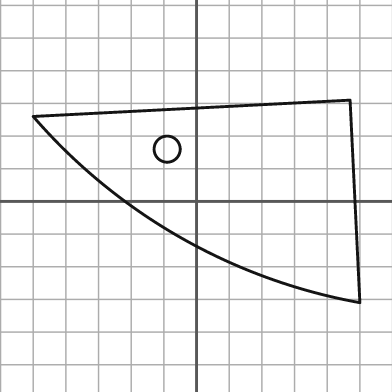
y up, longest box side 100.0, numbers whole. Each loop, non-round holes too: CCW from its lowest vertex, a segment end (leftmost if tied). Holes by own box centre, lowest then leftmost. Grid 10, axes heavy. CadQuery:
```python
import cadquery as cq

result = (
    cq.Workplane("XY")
    .moveTo(50.0, -31.0)
    .lineTo(47.0, 31.0)
    .lineTo(-50.0, 26.0)
    .threePointArc((-5.0, -11.0), (50.0, -31.0))
    .close()
    .moveTo(-9.0, 16.0)
    .circle(4.0)
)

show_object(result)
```